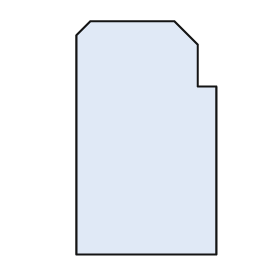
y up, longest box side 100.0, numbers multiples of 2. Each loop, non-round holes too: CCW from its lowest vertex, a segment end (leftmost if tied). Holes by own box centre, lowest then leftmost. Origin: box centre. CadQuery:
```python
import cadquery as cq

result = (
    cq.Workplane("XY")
    .moveTo(-30.0, -50.0)
    .lineTo(30.0, -50.0)
    .lineTo(30.0, 22.0)
    .lineTo(22.0, 22.0)
    .lineTo(22.0, 40.0)
    .lineTo(12.0, 50.0)
    .lineTo(-24.0, 50.0)
    .lineTo(-30.0, 44.0)
    .close()
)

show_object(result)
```